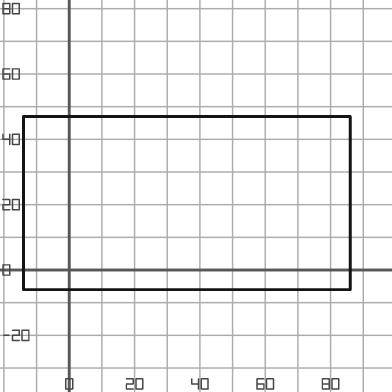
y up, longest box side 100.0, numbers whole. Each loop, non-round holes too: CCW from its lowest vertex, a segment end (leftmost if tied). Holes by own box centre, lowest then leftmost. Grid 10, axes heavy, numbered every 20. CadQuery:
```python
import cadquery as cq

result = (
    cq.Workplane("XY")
    .moveTo(-14.0, -6.0)
    .lineTo(86.0, -6.0)
    .lineTo(86.0, 47.0)
    .lineTo(-14.0, 47.0)
    .close()
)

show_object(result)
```